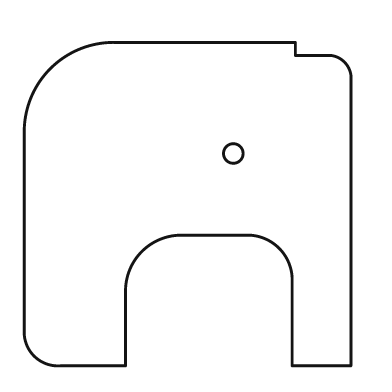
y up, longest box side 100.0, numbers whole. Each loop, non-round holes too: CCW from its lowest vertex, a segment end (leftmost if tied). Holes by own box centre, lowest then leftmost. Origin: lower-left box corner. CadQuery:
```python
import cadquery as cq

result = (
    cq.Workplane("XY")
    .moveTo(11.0, 0.0)
    .lineTo(31.0, 0.0)
    .lineTo(31.0, 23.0)
    .threePointArc((36.0, 35.0), (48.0, 40.0))
    .lineTo(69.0, 40.0)
    .threePointArc((78.0, 36.0), (82.0, 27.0))
    .lineTo(82.0, 0.0)
    .lineTo(100.0, 0.0)
    .lineTo(100.0, 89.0)
    .threePointArc((98.0, 93.0), (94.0, 95.0))
    .lineTo(83.0, 95.0)
    .lineTo(83.0, 99.0)
    .lineTo(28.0, 99.0)
    .threePointArc((8.0, 91.0), (0.0, 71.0))
    .lineTo(0.0, 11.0)
    .threePointArc((3.0, 3.0), (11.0, 0.0))
    .close()
    .moveTo(64.0, 65.0)
    .circle(3.0)
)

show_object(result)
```